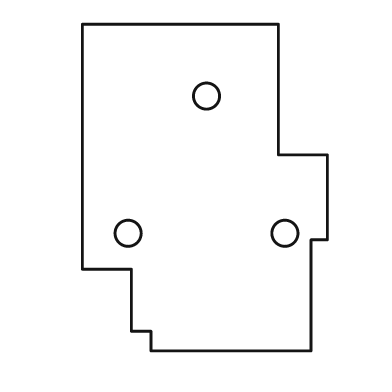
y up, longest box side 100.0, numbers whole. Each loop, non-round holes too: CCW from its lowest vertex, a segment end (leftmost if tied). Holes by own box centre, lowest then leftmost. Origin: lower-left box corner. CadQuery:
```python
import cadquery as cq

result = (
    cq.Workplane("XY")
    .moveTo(21.0, 0.0)
    .lineTo(70.0, 0.0)
    .lineTo(70.0, 34.0)
    .lineTo(75.0, 34.0)
    .lineTo(75.0, 60.0)
    .lineTo(60.0, 60.0)
    .lineTo(60.0, 100.0)
    .lineTo(0.0, 100.0)
    .lineTo(0.0, 25.0)
    .lineTo(15.0, 25.0)
    .lineTo(15.0, 6.0)
    .lineTo(21.0, 6.0)
    .close()
    .moveTo(14.0, 36.0)
    .circle(4.0)
    .moveTo(62.0, 36.0)
    .circle(4.0)
    .moveTo(38.0, 78.0)
    .circle(4.0)
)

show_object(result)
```